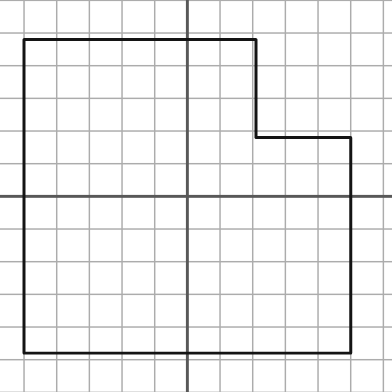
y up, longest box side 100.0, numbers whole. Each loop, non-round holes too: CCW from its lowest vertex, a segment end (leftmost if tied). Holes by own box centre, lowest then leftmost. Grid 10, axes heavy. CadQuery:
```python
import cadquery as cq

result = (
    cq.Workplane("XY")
    .moveTo(-50.0, -48.0)
    .lineTo(50.0, -48.0)
    .lineTo(50.0, 18.0)
    .lineTo(21.0, 18.0)
    .lineTo(21.0, 48.0)
    .lineTo(-50.0, 48.0)
    .close()
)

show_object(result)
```